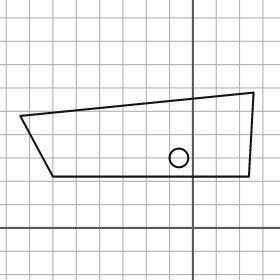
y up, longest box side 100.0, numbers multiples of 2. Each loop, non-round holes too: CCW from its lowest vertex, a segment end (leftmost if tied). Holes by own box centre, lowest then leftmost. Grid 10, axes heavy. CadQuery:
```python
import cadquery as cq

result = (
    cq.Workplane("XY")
    .moveTo(-60.0, 22.0)
    .lineTo(24.0, 22.0)
    .lineTo(26.0, 58.0)
    .lineTo(-74.0, 48.0)
    .close()
    .moveTo(-6.0, 30.0)
    .circle(4.0)
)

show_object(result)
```